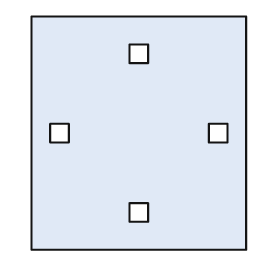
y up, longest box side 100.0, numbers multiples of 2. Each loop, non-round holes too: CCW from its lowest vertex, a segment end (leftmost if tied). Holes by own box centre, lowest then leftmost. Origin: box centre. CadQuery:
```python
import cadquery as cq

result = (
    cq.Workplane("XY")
    .moveTo(-46.0, -50.0)
    .lineTo(46.0, -50.0)
    .lineTo(46.0, 50.0)
    .lineTo(-46.0, 50.0)
    .close()
    .moveTo(-4.0, -38.0)
    .lineTo(4.0, -38.0)
    .lineTo(4.0, -30.0)
    .lineTo(-4.0, -30.0)
    .close()
    .moveTo(-38.0, -4.0)
    .lineTo(-30.0, -4.0)
    .lineTo(-30.0, 4.0)
    .lineTo(-38.0, 4.0)
    .close()
    .moveTo(30.0, -4.0)
    .lineTo(38.0, -4.0)
    .lineTo(38.0, 4.0)
    .lineTo(30.0, 4.0)
    .close()
    .moveTo(-4.0, 30.0)
    .lineTo(4.0, 30.0)
    .lineTo(4.0, 38.0)
    .lineTo(-4.0, 38.0)
    .close()
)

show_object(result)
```